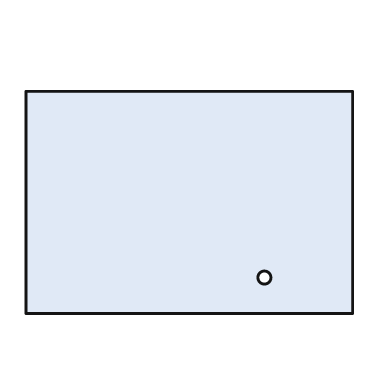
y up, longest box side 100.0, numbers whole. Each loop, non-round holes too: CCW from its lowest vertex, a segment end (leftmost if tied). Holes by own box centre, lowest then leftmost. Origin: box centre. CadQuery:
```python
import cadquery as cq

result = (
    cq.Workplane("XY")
    .moveTo(-50.0, -34.0)
    .lineTo(50.0, -34.0)
    .lineTo(50.0, 34.0)
    .lineTo(-50.0, 34.0)
    .close()
    .moveTo(23.0, -23.0)
    .circle(2.0)
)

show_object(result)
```